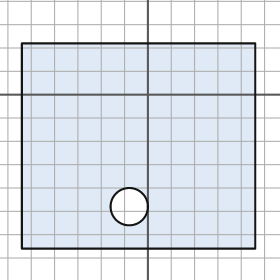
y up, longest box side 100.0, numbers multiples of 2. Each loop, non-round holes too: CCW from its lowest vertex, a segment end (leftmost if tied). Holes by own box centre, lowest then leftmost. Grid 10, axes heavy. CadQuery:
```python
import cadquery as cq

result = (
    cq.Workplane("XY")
    .moveTo(-54.0, -66.0)
    .lineTo(46.0, -66.0)
    .lineTo(46.0, 22.0)
    .lineTo(-54.0, 22.0)
    .close()
    .moveTo(-8.0, -48.0)
    .circle(8.0)
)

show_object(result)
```